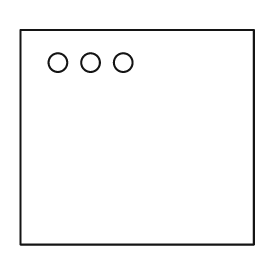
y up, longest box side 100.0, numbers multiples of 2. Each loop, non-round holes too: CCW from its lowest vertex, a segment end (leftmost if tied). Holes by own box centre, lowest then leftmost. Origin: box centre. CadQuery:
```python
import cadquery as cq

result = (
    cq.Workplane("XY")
    .moveTo(-50.0, -46.0)
    .lineTo(50.0, -46.0)
    .lineTo(50.0, 46.0)
    .lineTo(-50.0, 46.0)
    .close()
    .moveTo(-34.0, 32.0)
    .circle(4.0)
    .moveTo(-20.0, 32.0)
    .circle(4.0)
    .moveTo(-6.0, 32.0)
    .circle(4.0)
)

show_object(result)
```